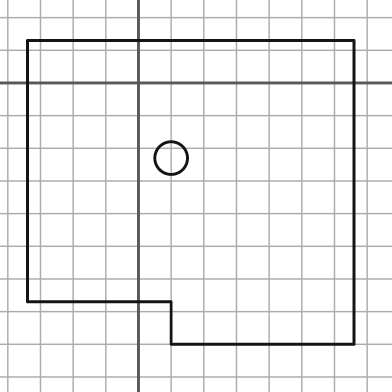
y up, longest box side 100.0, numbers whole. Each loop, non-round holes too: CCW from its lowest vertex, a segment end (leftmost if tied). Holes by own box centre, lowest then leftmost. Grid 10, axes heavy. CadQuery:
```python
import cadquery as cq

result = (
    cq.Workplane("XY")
    .moveTo(10.0, -80.0)
    .lineTo(66.0, -80.0)
    .lineTo(66.0, 13.0)
    .lineTo(-34.0, 13.0)
    .lineTo(-34.0, -67.0)
    .lineTo(10.0, -67.0)
    .close()
    .moveTo(10.0, -23.0)
    .circle(5.0)
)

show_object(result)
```